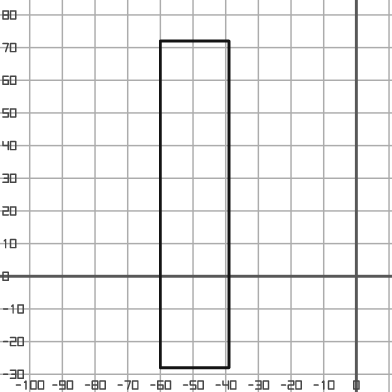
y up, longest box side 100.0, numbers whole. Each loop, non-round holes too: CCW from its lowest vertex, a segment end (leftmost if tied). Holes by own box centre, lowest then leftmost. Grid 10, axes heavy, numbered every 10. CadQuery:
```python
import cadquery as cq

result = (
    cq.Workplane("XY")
    .moveTo(-60.0, -28.0)
    .lineTo(-39.0, -28.0)
    .lineTo(-39.0, 72.0)
    .lineTo(-60.0, 72.0)
    .close()
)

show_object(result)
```